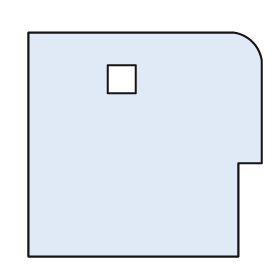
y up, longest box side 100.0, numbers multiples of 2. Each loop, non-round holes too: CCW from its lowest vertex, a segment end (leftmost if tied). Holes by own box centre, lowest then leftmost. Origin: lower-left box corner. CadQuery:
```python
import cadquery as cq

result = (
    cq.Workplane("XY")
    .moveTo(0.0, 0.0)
    .lineTo(90.0, 0.0)
    .lineTo(90.0, 40.0)
    .lineTo(100.0, 40.0)
    .lineTo(100.0, 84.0)
    .threePointArc((96.0, 92.0), (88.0, 96.0))
    .lineTo(0.0, 96.0)
    .close()
    .moveTo(34.0, 70.0)
    .lineTo(46.0, 70.0)
    .lineTo(46.0, 82.0)
    .lineTo(34.0, 82.0)
    .close()
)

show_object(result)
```